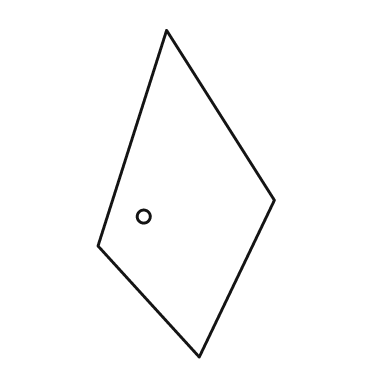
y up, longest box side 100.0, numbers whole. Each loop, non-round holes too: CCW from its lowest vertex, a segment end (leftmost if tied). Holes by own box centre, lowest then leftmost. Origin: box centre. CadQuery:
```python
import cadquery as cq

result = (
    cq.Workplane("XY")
    .moveTo(4.0, -50.0)
    .lineTo(27.0, -2.0)
    .lineTo(-6.0, 50.0)
    .lineTo(-27.0, -16.0)
    .close()
    .moveTo(-13.0, -7.0)
    .circle(2.0)
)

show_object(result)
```